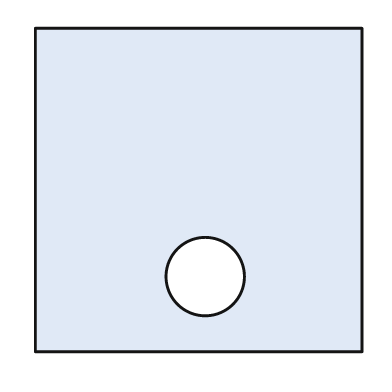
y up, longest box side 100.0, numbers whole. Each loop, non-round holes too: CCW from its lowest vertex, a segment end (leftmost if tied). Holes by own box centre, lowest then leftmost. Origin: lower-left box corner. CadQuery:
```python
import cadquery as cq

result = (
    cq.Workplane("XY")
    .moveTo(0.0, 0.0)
    .lineTo(100.0, 0.0)
    .lineTo(100.0, 99.0)
    .lineTo(0.0, 99.0)
    .close()
    .moveTo(52.0, 23.0)
    .circle(12.0)
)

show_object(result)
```